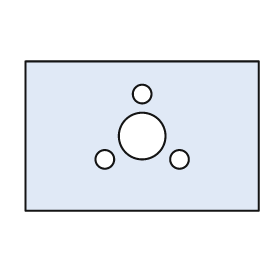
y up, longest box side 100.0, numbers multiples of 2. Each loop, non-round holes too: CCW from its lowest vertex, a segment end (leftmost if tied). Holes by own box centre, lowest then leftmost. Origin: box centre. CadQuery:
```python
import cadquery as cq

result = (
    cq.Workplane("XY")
    .moveTo(-50.0, -32.0)
    .lineTo(50.0, -32.0)
    .lineTo(50.0, 32.0)
    .lineTo(-50.0, 32.0)
    .close()
    .moveTo(-16.0, -10.0)
    .circle(4.0)
    .moveTo(16.0, -10.0)
    .circle(4.0)
    .moveTo(0.0, 0.0)
    .circle(10.0)
    .moveTo(0.0, 18.0)
    .circle(4.0)
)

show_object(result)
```